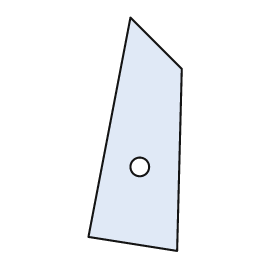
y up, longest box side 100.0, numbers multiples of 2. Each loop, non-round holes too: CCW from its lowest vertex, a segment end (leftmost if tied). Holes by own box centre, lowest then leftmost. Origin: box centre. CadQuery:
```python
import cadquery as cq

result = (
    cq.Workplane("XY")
    .moveTo(18.0, -50.0)
    .lineTo(20.0, 28.0)
    .lineTo(-2.0, 50.0)
    .lineTo(-20.0, -44.0)
    .close()
    .moveTo(2.0, -14.0)
    .circle(4.0)
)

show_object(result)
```